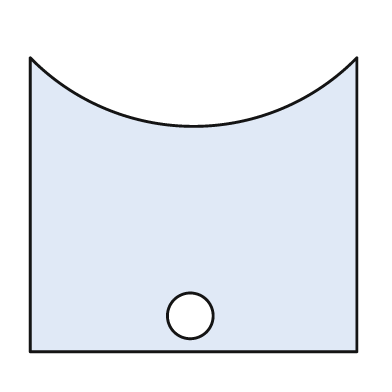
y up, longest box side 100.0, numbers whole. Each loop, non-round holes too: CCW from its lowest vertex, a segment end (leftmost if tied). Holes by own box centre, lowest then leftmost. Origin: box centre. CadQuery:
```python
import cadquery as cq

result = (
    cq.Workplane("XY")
    .moveTo(-50.0, -45.0)
    .lineTo(50.0, -45.0)
    .lineTo(50.0, 45.0)
    .threePointArc((0.0, 24.0), (-50.0, 45.0))
    .close()
    .moveTo(-1.0, -34.0)
    .circle(7.0)
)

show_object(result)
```